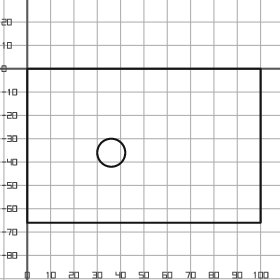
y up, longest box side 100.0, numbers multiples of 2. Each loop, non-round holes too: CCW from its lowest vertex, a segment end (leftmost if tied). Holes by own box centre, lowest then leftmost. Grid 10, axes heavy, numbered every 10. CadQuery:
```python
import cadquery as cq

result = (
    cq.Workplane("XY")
    .moveTo(0.0, -66.0)
    .lineTo(100.0, -66.0)
    .lineTo(100.0, 0.0)
    .lineTo(0.0, 0.0)
    .close()
    .moveTo(36.0, -36.0)
    .circle(6.0)
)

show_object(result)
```